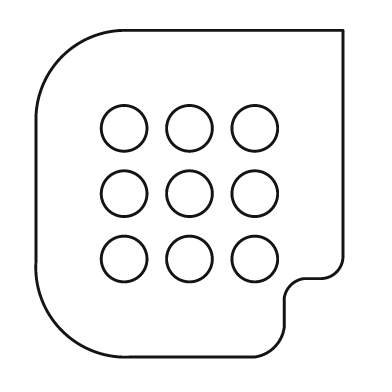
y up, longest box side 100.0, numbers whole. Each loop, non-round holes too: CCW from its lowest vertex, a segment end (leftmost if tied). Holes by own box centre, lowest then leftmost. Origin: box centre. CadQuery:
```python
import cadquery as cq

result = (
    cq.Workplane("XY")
    .moveTo(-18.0, -50.0)
    .lineTo(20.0, -50.0)
    .threePointArc((26.0, -47.0), (29.0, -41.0))
    .lineTo(29.0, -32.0)
    .threePointArc((31.0, -28.0), (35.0, -26.0))
    .lineTo(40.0, -26.0)
    .threePointArc((45.0, -24.0), (47.0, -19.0))
    .lineTo(47.0, 50.0)
    .lineTo(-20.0, 50.0)
    .threePointArc((-39.0, 42.0), (-47.0, 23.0))
    .lineTo(-47.0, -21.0)
    .threePointArc((-39.0, -42.0), (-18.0, -50.0))
    .close()
    .moveTo(-20.0, -20.0)
    .circle(7.0)
    .moveTo(0.0, -20.0)
    .circle(7.0)
    .moveTo(20.0, -20.0)
    .circle(7.0)
    .moveTo(-20.0, 0.0)
    .circle(7.0)
    .moveTo(0.0, 0.0)
    .circle(7.0)
    .moveTo(20.0, 0.0)
    .circle(7.0)
    .moveTo(-20.0, 20.0)
    .circle(7.0)
    .moveTo(0.0, 20.0)
    .circle(7.0)
    .moveTo(20.0, 20.0)
    .circle(7.0)
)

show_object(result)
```